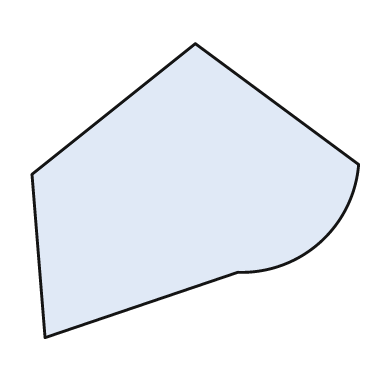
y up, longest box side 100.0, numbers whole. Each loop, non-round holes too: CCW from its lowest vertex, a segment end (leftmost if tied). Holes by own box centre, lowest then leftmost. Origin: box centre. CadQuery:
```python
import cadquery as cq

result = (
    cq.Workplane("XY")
    .moveTo(-46.0, -45.0)
    .lineTo(13.0, -25.0)
    .threePointArc((38.0, -16.0), (50.0, 8.0))
    .lineTo(0.0, 45.0)
    .lineTo(-50.0, 5.0)
    .close()
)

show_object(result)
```